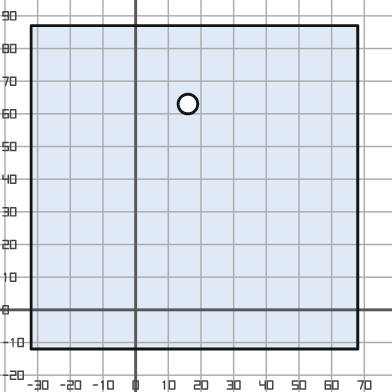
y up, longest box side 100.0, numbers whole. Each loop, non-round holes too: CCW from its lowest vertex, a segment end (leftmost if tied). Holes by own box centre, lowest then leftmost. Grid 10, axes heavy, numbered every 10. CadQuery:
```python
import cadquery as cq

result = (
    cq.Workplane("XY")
    .moveTo(-32.0, -12.0)
    .lineTo(68.0, -12.0)
    .lineTo(68.0, 87.0)
    .lineTo(-32.0, 87.0)
    .close()
    .moveTo(16.0, 63.0)
    .circle(3.0)
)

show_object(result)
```